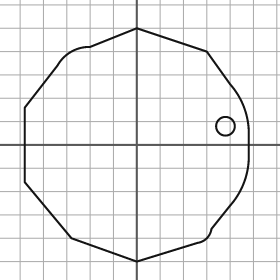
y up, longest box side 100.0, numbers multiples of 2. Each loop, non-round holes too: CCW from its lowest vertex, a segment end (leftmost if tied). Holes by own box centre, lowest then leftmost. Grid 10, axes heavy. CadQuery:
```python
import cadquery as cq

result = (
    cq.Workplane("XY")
    .moveTo(0.0, -50.0)
    .lineTo(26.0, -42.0)
    .threePointArc((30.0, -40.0), (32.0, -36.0))
    .lineTo(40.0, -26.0)
    .threePointArc((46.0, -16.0), (48.0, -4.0))
    .lineTo(48.0, 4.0)
    .threePointArc((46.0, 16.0), (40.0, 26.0))
    .lineTo(30.0, 40.0)
    .lineTo(0.0, 50.0)
    .lineTo(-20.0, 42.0)
    .threePointArc((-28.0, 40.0), (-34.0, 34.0))
    .lineTo(-48.0, 16.0)
    .lineTo(-48.0, -16.0)
    .lineTo(-28.0, -40.0)
    .close()
    .moveTo(38.0, 8.0)
    .circle(4.0)
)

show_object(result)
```